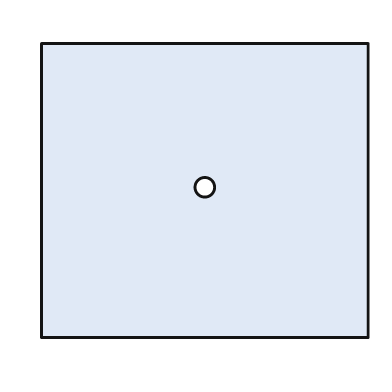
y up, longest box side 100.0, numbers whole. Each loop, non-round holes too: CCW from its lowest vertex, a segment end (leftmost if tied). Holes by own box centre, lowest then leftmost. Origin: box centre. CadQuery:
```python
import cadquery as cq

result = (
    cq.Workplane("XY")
    .moveTo(-50.0, -45.0)
    .lineTo(50.0, -45.0)
    .lineTo(50.0, 45.0)
    .lineTo(-50.0, 45.0)
    .close()
    .moveTo(0.0, 1.0)
    .circle(3.0)
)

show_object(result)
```